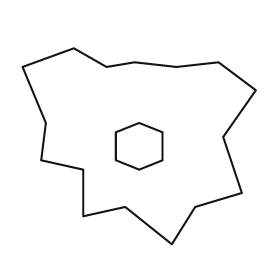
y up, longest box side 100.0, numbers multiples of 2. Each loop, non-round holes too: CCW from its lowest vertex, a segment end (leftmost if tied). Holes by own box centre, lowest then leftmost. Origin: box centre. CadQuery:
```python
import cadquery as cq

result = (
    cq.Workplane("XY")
    .moveTo(14.0, -42.0)
    .lineTo(24.0, -26.0)
    .lineTo(44.0, -20.0)
    .lineTo(36.0, 4.0)
    .lineTo(50.0, 24.0)
    .lineTo(34.0, 36.0)
    .lineTo(16.0, 34.0)
    .lineTo(-2.0, 36.0)
    .lineTo(-14.0, 34.0)
    .lineTo(-28.0, 42.0)
    .lineTo(-50.0, 34.0)
    .lineTo(-40.0, 10.0)
    .lineTo(-42.0, -6.0)
    .lineTo(-24.0, -10.0)
    .lineTo(-24.0, -30.0)
    .lineTo(-6.0, -26.0)
    .close()
    .moveTo(0.0, -10.0)
    .lineTo(10.0, -6.0)
    .lineTo(10.0, 6.0)
    .lineTo(0.0, 10.0)
    .lineTo(-10.0, 6.0)
    .lineTo(-10.0, -6.0)
    .close()
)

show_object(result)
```